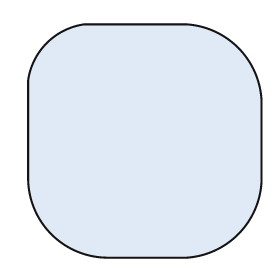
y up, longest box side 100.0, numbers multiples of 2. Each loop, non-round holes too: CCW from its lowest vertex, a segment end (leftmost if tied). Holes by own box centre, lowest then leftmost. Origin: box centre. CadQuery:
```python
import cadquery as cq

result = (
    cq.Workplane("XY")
    .moveTo(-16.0, -50.0)
    .lineTo(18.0, -50.0)
    .threePointArc((40.0, -40.0), (50.0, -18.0))
    .lineTo(50.0, 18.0)
    .threePointArc((40.0, 40.0), (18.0, 50.0))
    .lineTo(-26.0, 50.0)
    .threePointArc((-42.0, 42.0), (-50.0, 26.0))
    .lineTo(-50.0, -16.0)
    .threePointArc((-40.0, -40.0), (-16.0, -50.0))
    .close()
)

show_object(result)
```